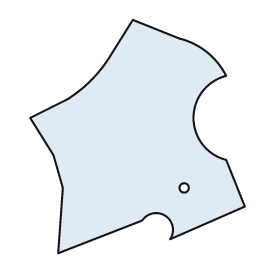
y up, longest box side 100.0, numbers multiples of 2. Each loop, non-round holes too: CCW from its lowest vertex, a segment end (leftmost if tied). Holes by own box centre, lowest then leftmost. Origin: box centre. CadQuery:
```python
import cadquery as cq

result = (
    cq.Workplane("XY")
    .moveTo(-34.0, -50.0)
    .lineTo(2.0, -36.0)
    .threePointArc((12.0, -34.0), (14.0, -44.0))
    .lineTo(46.0, -30.0)
    .lineTo(38.0, -10.0)
    .threePointArc((24.0, 8.0), (38.0, 26.0))
    .threePointArc((30.0, 36.0), (18.0, 42.0))
    .lineTo(-2.0, 50.0)
    .lineTo(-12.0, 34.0)
    .threePointArc((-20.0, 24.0), (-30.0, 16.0))
    .lineTo(-46.0, 8.0)
    .lineTo(-36.0, -8.0)
    .lineTo(-32.0, -22.0)
    .close()
    .moveTo(20.0, -22.0)
    .circle(2.0)
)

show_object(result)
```